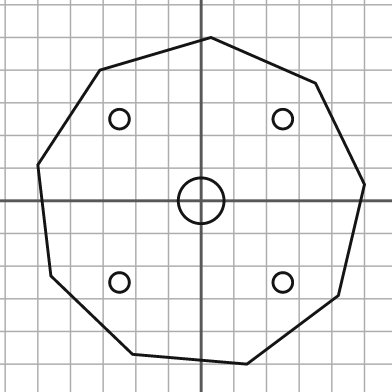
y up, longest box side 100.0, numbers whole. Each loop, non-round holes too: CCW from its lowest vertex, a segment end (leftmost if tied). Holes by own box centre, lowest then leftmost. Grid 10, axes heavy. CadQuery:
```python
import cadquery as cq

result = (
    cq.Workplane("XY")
    .moveTo(14.0, -50.0)
    .lineTo(42.0, -29.0)
    .lineTo(50.0, 5.0)
    .lineTo(35.0, 36.0)
    .lineTo(3.0, 50.0)
    .lineTo(-31.0, 40.0)
    .lineTo(-50.0, 11.0)
    .lineTo(-46.0, -23.0)
    .lineTo(-21.0, -47.0)
    .close()
    .moveTo(-25.0, -25.0)
    .circle(3.0)
    .moveTo(25.0, -25.0)
    .circle(3.0)
    .moveTo(0.0, 0.0)
    .circle(7.0)
    .moveTo(-25.0, 25.0)
    .circle(3.0)
    .moveTo(25.0, 25.0)
    .circle(3.0)
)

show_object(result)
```